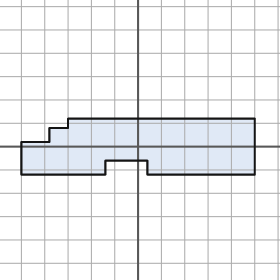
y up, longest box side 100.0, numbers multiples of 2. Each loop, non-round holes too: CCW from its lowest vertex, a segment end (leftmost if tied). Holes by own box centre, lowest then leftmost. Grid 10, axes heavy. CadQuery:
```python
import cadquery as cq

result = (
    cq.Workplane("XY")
    .moveTo(-50.0, -12.0)
    .lineTo(-14.0, -12.0)
    .lineTo(-14.0, -6.0)
    .lineTo(4.0, -6.0)
    .lineTo(4.0, -12.0)
    .lineTo(50.0, -12.0)
    .lineTo(50.0, 12.0)
    .lineTo(-30.0, 12.0)
    .lineTo(-30.0, 8.0)
    .lineTo(-38.0, 8.0)
    .lineTo(-38.0, 2.0)
    .lineTo(-50.0, 2.0)
    .close()
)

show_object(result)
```